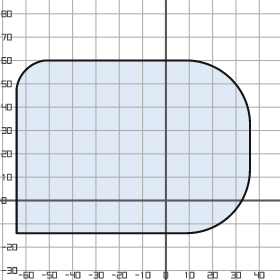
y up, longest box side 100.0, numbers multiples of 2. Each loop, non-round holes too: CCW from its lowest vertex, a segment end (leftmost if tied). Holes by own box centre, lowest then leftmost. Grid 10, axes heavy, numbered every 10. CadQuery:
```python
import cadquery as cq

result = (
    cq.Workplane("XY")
    .moveTo(-64.0, -14.0)
    .lineTo(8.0, -14.0)
    .threePointArc((28.0, -6.0), (36.0, 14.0))
    .lineTo(36.0, 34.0)
    .threePointArc((28.0, 52.0), (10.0, 60.0))
    .lineTo(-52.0, 60.0)
    .threePointArc((-60.0, 56.0), (-64.0, 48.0))
    .close()
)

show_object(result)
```